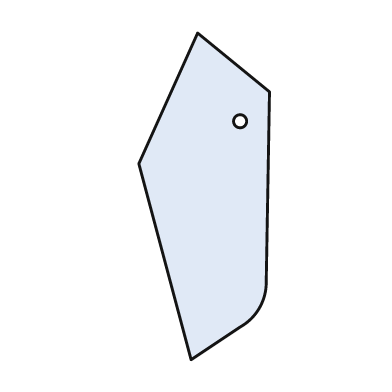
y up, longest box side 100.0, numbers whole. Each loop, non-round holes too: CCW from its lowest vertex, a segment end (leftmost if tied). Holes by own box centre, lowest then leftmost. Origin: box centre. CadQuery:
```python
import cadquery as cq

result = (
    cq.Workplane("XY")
    .moveTo(-4.0, -50.0)
    .lineTo(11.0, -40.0)
    .threePointArc((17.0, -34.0), (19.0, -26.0))
    .lineTo(20.0, 32.0)
    .lineTo(-2.0, 50.0)
    .lineTo(-20.0, 10.0)
    .close()
    .moveTo(11.0, 23.0)
    .circle(2.0)
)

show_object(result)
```